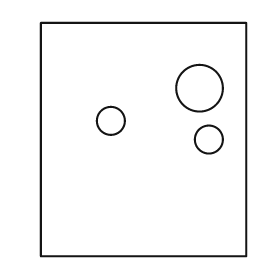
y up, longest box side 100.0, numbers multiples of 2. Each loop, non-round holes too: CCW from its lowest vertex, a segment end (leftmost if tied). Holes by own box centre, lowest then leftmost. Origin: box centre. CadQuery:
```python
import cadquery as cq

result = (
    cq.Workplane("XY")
    .moveTo(-44.0, -50.0)
    .lineTo(44.0, -50.0)
    .lineTo(44.0, 50.0)
    .lineTo(-44.0, 50.0)
    .close()
    .moveTo(28.0, 0.0)
    .circle(6.0)
    .moveTo(-14.0, 8.0)
    .circle(6.0)
    .moveTo(24.0, 22.0)
    .circle(10.0)
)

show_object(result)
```